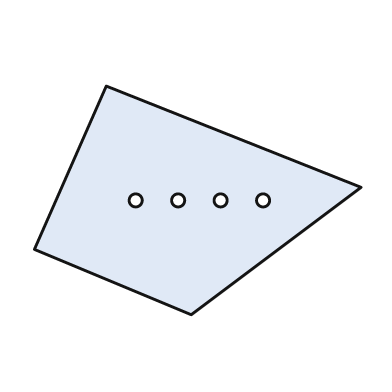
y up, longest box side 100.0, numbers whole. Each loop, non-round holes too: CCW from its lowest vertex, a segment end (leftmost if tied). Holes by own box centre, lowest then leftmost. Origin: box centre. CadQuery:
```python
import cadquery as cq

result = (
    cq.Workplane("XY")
    .moveTo(-2.0, -35.0)
    .lineTo(50.0, 4.0)
    .lineTo(-28.0, 35.0)
    .lineTo(-50.0, -15.0)
    .close()
    .moveTo(-19.0, 0.0)
    .circle(2.0)
    .moveTo(-6.0, 0.0)
    .circle(2.0)
    .moveTo(7.0, 0.0)
    .circle(2.0)
    .moveTo(20.0, 0.0)
    .circle(2.0)
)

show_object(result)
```